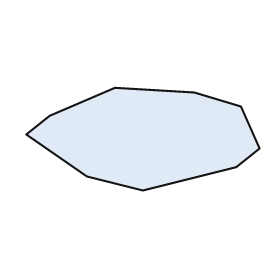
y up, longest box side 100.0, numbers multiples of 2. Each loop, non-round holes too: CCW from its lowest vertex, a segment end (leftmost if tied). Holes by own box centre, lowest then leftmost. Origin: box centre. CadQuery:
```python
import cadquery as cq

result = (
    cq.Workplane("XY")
    .moveTo(0.0, -22.0)
    .lineTo(40.0, -12.0)
    .lineTo(50.0, -4.0)
    .lineTo(42.0, 14.0)
    .lineTo(22.0, 20.0)
    .lineTo(-12.0, 22.0)
    .lineTo(-40.0, 10.0)
    .lineTo(-50.0, 2.0)
    .lineTo(-24.0, -16.0)
    .close()
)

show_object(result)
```